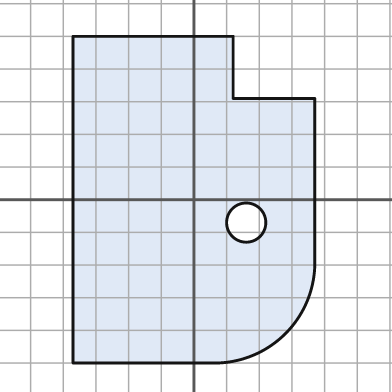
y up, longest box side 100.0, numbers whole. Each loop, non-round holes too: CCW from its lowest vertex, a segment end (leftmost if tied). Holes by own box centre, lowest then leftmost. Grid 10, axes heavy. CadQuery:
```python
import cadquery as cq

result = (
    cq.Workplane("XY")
    .moveTo(-37.0, -50.0)
    .lineTo(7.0, -50.0)
    .threePointArc((28.0, -41.0), (37.0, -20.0))
    .lineTo(37.0, 31.0)
    .lineTo(12.0, 31.0)
    .lineTo(12.0, 50.0)
    .lineTo(-37.0, 50.0)
    .close()
    .moveTo(16.0, -7.0)
    .circle(6.0)
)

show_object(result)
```